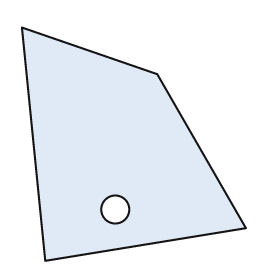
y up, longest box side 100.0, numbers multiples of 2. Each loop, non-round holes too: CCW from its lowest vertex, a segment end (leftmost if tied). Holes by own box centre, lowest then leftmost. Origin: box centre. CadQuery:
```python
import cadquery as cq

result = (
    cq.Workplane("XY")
    .moveTo(-38.0, -50.0)
    .lineTo(48.0, -36.0)
    .lineTo(10.0, 30.0)
    .lineTo(-48.0, 50.0)
    .close()
    .moveTo(-8.0, -28.0)
    .circle(6.0)
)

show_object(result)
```